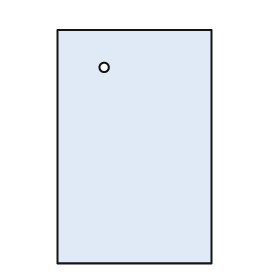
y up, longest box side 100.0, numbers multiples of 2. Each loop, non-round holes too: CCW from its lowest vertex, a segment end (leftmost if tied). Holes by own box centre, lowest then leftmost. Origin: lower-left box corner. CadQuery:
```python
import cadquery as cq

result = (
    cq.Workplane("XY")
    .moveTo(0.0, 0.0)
    .lineTo(66.0, 0.0)
    .lineTo(66.0, 100.0)
    .lineTo(0.0, 100.0)
    .close()
    .moveTo(20.0, 84.0)
    .circle(2.0)
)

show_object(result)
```